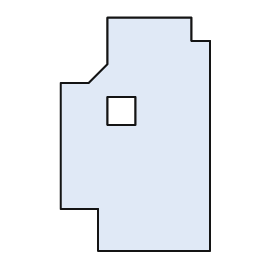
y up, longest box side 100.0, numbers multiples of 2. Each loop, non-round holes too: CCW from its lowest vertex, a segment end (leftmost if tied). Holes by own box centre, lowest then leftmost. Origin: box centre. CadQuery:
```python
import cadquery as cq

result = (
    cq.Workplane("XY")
    .moveTo(-16.0, -50.0)
    .lineTo(32.0, -50.0)
    .lineTo(32.0, 40.0)
    .lineTo(24.0, 40.0)
    .lineTo(24.0, 50.0)
    .lineTo(-12.0, 50.0)
    .lineTo(-12.0, 30.0)
    .lineTo(-20.0, 22.0)
    .lineTo(-32.0, 22.0)
    .lineTo(-32.0, -32.0)
    .lineTo(-16.0, -32.0)
    .close()
    .moveTo(-12.0, 4.0)
    .lineTo(0.0, 4.0)
    .lineTo(0.0, 16.0)
    .lineTo(-12.0, 16.0)
    .close()
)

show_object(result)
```